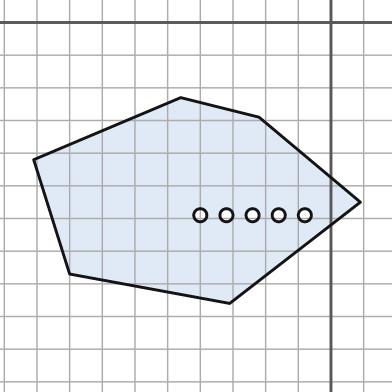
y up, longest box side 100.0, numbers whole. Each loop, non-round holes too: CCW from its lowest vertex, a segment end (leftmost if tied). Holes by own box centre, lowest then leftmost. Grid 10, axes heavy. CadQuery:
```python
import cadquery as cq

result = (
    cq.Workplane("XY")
    .moveTo(-31.0, -86.0)
    .lineTo(9.0, -55.0)
    .lineTo(-22.0, -29.0)
    .lineTo(-46.0, -23.0)
    .lineTo(-91.0, -42.0)
    .lineTo(-80.0, -77.0)
    .close()
    .moveTo(-40.0, -59.0)
    .circle(2.0)
    .moveTo(-32.0, -59.0)
    .circle(2.0)
    .moveTo(-24.0, -59.0)
    .circle(2.0)
    .moveTo(-16.0, -59.0)
    .circle(2.0)
    .moveTo(-8.0, -59.0)
    .circle(2.0)
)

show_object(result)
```